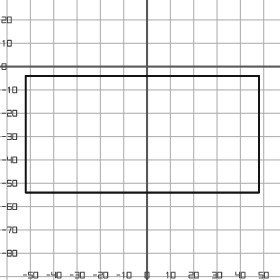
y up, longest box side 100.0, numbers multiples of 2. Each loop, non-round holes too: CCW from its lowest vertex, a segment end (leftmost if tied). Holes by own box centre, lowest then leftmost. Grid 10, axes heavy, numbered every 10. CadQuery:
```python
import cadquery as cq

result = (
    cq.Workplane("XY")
    .moveTo(-52.0, -54.0)
    .lineTo(48.0, -54.0)
    .lineTo(48.0, -4.0)
    .lineTo(-52.0, -4.0)
    .close()
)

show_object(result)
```